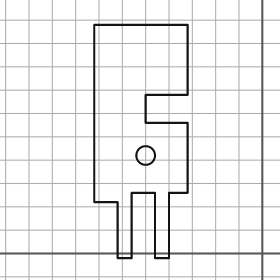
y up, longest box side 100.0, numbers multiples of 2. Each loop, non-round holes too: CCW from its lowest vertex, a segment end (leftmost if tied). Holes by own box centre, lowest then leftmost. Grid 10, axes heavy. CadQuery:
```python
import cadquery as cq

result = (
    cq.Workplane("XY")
    .moveTo(-62.0, -2.0)
    .lineTo(-56.0, -2.0)
    .lineTo(-56.0, 26.0)
    .lineTo(-46.0, 26.0)
    .lineTo(-46.0, -2.0)
    .lineTo(-40.0, -2.0)
    .lineTo(-40.0, 26.0)
    .lineTo(-32.0, 26.0)
    .lineTo(-32.0, 56.0)
    .lineTo(-50.0, 56.0)
    .lineTo(-50.0, 68.0)
    .lineTo(-32.0, 68.0)
    .lineTo(-32.0, 98.0)
    .lineTo(-72.0, 98.0)
    .lineTo(-72.0, 22.0)
    .lineTo(-62.0, 22.0)
    .close()
    .moveTo(-50.0, 42.0)
    .circle(4.0)
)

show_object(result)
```